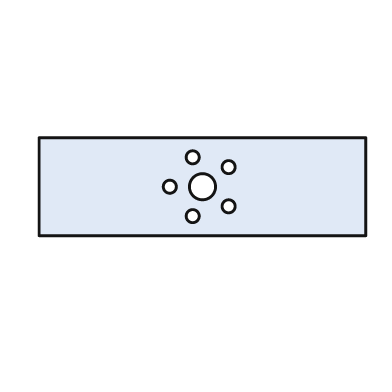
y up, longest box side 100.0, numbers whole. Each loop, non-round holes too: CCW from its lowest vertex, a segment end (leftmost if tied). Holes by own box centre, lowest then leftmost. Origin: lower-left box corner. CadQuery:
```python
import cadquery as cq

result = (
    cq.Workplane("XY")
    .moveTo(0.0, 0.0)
    .lineTo(100.0, 0.0)
    .lineTo(100.0, 30.0)
    .lineTo(0.0, 30.0)
    .close()
    .moveTo(47.0, 6.0)
    .circle(2.0)
    .moveTo(58.0, 9.0)
    .circle(2.0)
    .moveTo(40.0, 15.0)
    .circle(2.0)
    .moveTo(50.0, 15.0)
    .circle(4.0)
    .moveTo(58.0, 21.0)
    .circle(2.0)
    .moveTo(47.0, 24.0)
    .circle(2.0)
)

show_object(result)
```